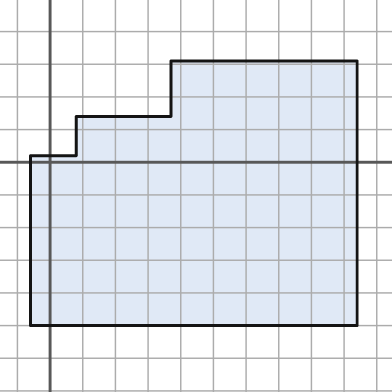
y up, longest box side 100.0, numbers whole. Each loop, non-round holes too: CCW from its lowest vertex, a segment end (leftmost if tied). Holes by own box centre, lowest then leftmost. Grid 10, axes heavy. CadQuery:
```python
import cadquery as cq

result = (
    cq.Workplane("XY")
    .moveTo(-6.0, -50.0)
    .lineTo(94.0, -50.0)
    .lineTo(94.0, 31.0)
    .lineTo(37.0, 31.0)
    .lineTo(37.0, 14.0)
    .lineTo(8.0, 14.0)
    .lineTo(8.0, 2.0)
    .lineTo(-6.0, 2.0)
    .close()
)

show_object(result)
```